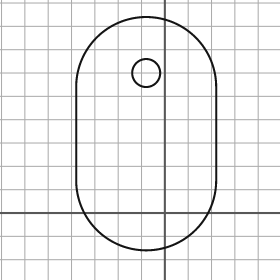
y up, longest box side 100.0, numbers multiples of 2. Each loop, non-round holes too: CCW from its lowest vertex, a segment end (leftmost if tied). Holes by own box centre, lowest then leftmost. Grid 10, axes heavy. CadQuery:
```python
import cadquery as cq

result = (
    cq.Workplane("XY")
    .moveTo(-38.0, 14.0)
    .threePointArc((-8.0, -16.0), (22.0, 14.0))
    .lineTo(22.0, 54.0)
    .threePointArc((-8.0, 84.0), (-38.0, 54.0))
    .close()
    .moveTo(-8.0, 60.0)
    .circle(6.0)
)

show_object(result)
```